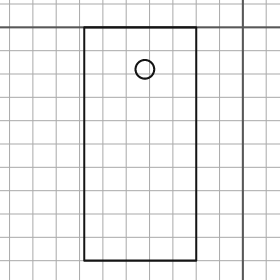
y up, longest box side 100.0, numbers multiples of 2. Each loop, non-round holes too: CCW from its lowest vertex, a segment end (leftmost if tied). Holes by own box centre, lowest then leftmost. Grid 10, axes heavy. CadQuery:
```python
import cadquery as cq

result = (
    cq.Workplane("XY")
    .moveTo(-68.0, -100.0)
    .lineTo(-20.0, -100.0)
    .lineTo(-20.0, 0.0)
    .lineTo(-68.0, 0.0)
    .close()
    .moveTo(-42.0, -18.0)
    .circle(4.0)
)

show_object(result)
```